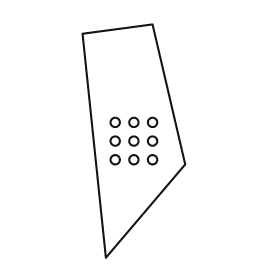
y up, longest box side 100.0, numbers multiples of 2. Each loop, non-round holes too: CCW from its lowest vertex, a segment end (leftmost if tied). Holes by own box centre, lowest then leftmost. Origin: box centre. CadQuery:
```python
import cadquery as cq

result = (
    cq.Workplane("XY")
    .moveTo(-12.0, -50.0)
    .lineTo(22.0, -10.0)
    .lineTo(8.0, 50.0)
    .lineTo(-22.0, 46.0)
    .close()
    .moveTo(-8.0, -8.0)
    .circle(2.0)
    .moveTo(0.0, -8.0)
    .circle(2.0)
    .moveTo(8.0, -8.0)
    .circle(2.0)
    .moveTo(-8.0, 0.0)
    .circle(2.0)
    .moveTo(0.0, 0.0)
    .circle(2.0)
    .moveTo(8.0, 0.0)
    .circle(2.0)
    .moveTo(-8.0, 8.0)
    .circle(2.0)
    .moveTo(0.0, 8.0)
    .circle(2.0)
    .moveTo(8.0, 8.0)
    .circle(2.0)
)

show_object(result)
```